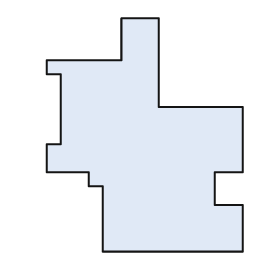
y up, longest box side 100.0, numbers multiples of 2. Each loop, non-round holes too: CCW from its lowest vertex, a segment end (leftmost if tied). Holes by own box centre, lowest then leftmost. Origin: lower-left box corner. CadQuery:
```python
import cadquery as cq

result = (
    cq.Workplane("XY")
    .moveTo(24.0, 0.0)
    .lineTo(84.0, 0.0)
    .lineTo(84.0, 20.0)
    .lineTo(72.0, 20.0)
    .lineTo(72.0, 34.0)
    .lineTo(84.0, 34.0)
    .lineTo(84.0, 62.0)
    .lineTo(48.0, 62.0)
    .lineTo(48.0, 100.0)
    .lineTo(32.0, 100.0)
    .lineTo(32.0, 82.0)
    .lineTo(0.0, 82.0)
    .lineTo(0.0, 76.0)
    .lineTo(6.0, 76.0)
    .lineTo(6.0, 46.0)
    .lineTo(0.0, 46.0)
    .lineTo(0.0, 34.0)
    .lineTo(18.0, 34.0)
    .lineTo(18.0, 28.0)
    .lineTo(24.0, 28.0)
    .close()
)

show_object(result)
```